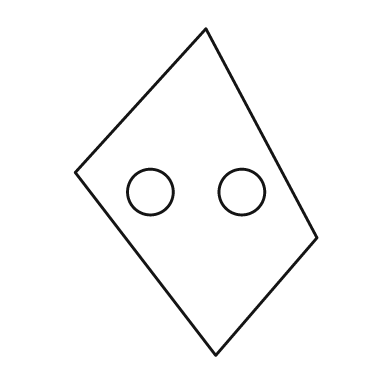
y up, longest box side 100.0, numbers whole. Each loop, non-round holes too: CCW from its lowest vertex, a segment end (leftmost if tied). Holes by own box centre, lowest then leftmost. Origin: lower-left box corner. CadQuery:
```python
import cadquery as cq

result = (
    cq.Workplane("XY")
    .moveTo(43.0, 0.0)
    .lineTo(74.0, 36.0)
    .lineTo(40.0, 100.0)
    .lineTo(0.0, 56.0)
    .close()
    .moveTo(23.0, 50.0)
    .circle(7.0)
    .moveTo(51.0, 50.0)
    .circle(7.0)
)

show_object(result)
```